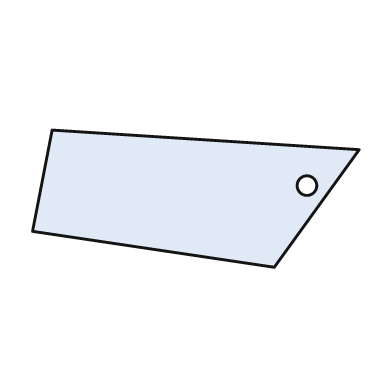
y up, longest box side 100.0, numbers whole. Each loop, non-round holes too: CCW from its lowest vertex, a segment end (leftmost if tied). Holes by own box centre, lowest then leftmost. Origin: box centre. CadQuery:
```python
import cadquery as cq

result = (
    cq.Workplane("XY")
    .moveTo(24.0, -21.0)
    .lineTo(50.0, 15.0)
    .lineTo(-44.0, 21.0)
    .lineTo(-50.0, -10.0)
    .close()
    .moveTo(34.0, 4.0)
    .circle(3.0)
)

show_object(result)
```